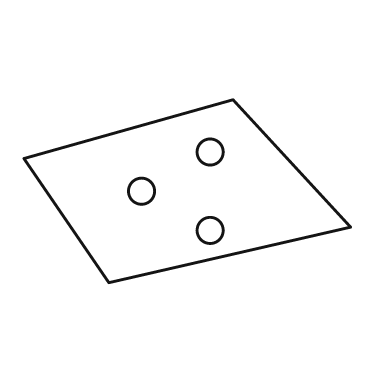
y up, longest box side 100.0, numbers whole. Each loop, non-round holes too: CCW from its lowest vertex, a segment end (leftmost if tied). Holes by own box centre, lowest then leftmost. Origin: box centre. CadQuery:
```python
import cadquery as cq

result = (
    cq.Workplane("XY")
    .moveTo(-24.0, -28.0)
    .lineTo(50.0, -11.0)
    .lineTo(14.0, 28.0)
    .lineTo(-50.0, 10.0)
    .close()
    .moveTo(7.0, -12.0)
    .circle(4.0)
    .moveTo(-14.0, 0.0)
    .circle(4.0)
    .moveTo(7.0, 12.0)
    .circle(4.0)
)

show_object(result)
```